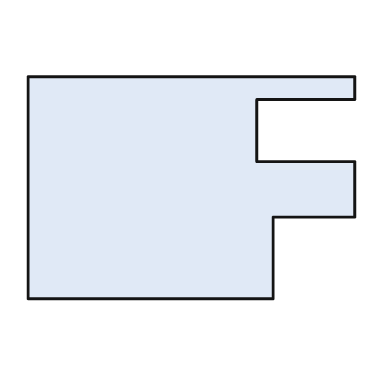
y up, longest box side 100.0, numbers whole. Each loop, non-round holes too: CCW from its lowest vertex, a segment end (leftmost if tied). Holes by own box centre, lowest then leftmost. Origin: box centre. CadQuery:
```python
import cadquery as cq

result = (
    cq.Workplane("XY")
    .moveTo(-50.0, -34.0)
    .lineTo(25.0, -34.0)
    .lineTo(25.0, -9.0)
    .lineTo(50.0, -9.0)
    .lineTo(50.0, 8.0)
    .lineTo(20.0, 8.0)
    .lineTo(20.0, 27.0)
    .lineTo(50.0, 27.0)
    .lineTo(50.0, 34.0)
    .lineTo(-50.0, 34.0)
    .close()
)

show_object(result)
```